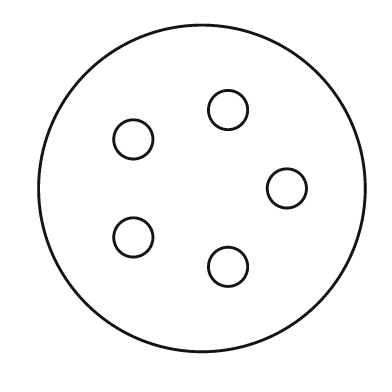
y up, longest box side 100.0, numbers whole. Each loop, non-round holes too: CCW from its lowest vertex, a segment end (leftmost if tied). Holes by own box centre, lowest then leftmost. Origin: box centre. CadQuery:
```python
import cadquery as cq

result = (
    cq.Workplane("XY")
    .moveTo(0.0, 0.0)
    .circle(50.0)
    .moveTo(8.0, -24.0)
    .circle(6.0)
    .moveTo(-21.0, -15.0)
    .circle(6.0)
    .moveTo(26.0, 0.0)
    .circle(6.0)
    .moveTo(-21.0, 15.0)
    .circle(6.0)
    .moveTo(8.0, 24.0)
    .circle(6.0)
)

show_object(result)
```